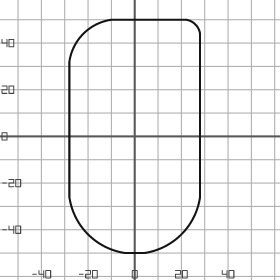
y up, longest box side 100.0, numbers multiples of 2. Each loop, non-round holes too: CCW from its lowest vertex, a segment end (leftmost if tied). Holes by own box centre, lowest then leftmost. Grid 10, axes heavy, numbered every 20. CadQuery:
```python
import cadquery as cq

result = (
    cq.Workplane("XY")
    .moveTo(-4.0, -50.0)
    .lineTo(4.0, -50.0)
    .threePointArc((20.0, -42.0), (28.0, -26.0))
    .lineTo(28.0, 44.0)
    .threePointArc((26.0, 48.0), (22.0, 50.0))
    .lineTo(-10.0, 50.0)
    .threePointArc((-22.0, 44.0), (-28.0, 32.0))
    .lineTo(-28.0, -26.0)
    .threePointArc((-20.0, -42.0), (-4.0, -50.0))
    .close()
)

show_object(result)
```